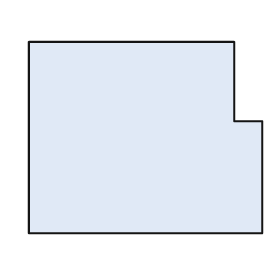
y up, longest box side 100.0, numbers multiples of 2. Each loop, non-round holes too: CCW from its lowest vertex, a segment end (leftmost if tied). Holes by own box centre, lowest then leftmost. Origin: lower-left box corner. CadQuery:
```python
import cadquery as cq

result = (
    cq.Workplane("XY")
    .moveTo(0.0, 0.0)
    .lineTo(100.0, 0.0)
    .lineTo(100.0, 48.0)
    .lineTo(88.0, 48.0)
    .lineTo(88.0, 82.0)
    .lineTo(0.0, 82.0)
    .close()
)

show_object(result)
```